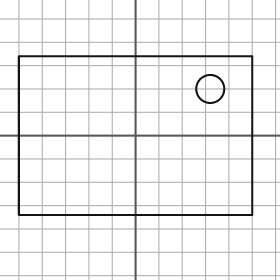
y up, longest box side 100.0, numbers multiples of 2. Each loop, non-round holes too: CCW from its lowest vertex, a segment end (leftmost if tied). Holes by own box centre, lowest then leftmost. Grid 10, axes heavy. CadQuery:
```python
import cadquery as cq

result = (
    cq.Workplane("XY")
    .moveTo(-50.0, -34.0)
    .lineTo(50.0, -34.0)
    .lineTo(50.0, 34.0)
    .lineTo(-50.0, 34.0)
    .close()
    .moveTo(32.0, 20.0)
    .circle(6.0)
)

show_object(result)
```